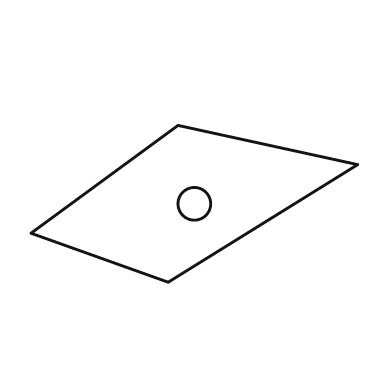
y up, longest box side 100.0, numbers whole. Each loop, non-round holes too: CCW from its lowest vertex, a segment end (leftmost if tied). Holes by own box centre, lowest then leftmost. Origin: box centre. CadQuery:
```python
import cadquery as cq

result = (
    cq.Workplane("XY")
    .moveTo(-8.0, -24.0)
    .lineTo(50.0, 12.0)
    .lineTo(-5.0, 24.0)
    .lineTo(-50.0, -9.0)
    .close()
    .moveTo(0.0, 0.0)
    .circle(5.0)
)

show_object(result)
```